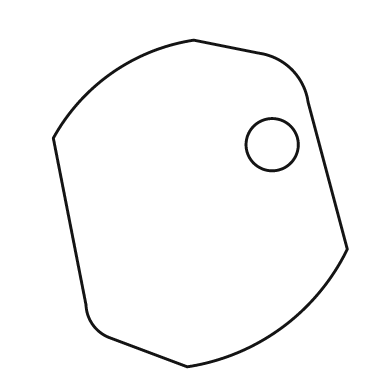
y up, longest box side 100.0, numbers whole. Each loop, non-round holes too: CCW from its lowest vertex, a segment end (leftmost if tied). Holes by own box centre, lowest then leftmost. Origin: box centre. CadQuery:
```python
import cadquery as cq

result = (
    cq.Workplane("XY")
    .moveTo(-4.0, -50.0)
    .threePointArc((25.0, -38.0), (45.0, -14.0))
    .lineTo(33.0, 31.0)
    .threePointArc((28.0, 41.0), (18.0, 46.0))
    .lineTo(-2.0, 50.0)
    .threePointArc((-27.0, 40.0), (-45.0, 20.0))
    .lineTo(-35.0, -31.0)
    .threePointArc((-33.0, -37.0), (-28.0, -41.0))
    .close()
    .moveTo(22.0, 18.0)
    .circle(8.0)
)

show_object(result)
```